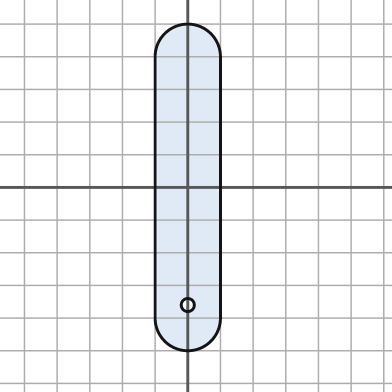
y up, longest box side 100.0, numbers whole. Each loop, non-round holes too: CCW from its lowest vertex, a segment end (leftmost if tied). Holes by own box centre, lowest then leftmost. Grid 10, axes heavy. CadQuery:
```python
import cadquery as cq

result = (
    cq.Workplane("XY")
    .moveTo(-10.0, -40.0)
    .threePointArc((0.0, -50.0), (10.0, -40.0))
    .lineTo(10.0, 40.0)
    .threePointArc((0.0, 50.0), (-10.0, 40.0))
    .close()
    .moveTo(0.0, -36.0)
    .circle(2.0)
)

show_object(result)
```